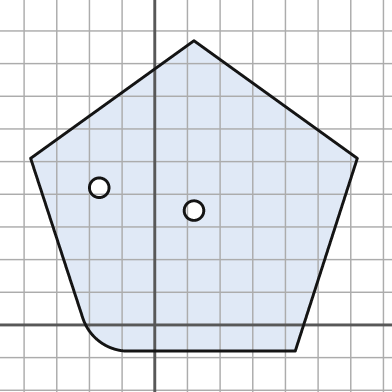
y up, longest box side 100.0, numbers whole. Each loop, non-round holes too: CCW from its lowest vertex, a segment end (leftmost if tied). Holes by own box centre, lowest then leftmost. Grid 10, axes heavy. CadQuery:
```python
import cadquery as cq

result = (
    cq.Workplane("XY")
    .moveTo(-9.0, -8.0)
    .lineTo(43.0, -8.0)
    .lineTo(62.0, 51.0)
    .lineTo(12.0, 87.0)
    .lineTo(-38.0, 51.0)
    .lineTo(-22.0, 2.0)
    .threePointArc((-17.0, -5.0), (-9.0, -8.0))
    .close()
    .moveTo(12.0, 35.0)
    .circle(3.0)
    .moveTo(-17.0, 42.0)
    .circle(3.0)
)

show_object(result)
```